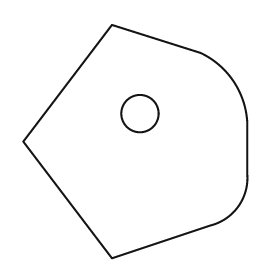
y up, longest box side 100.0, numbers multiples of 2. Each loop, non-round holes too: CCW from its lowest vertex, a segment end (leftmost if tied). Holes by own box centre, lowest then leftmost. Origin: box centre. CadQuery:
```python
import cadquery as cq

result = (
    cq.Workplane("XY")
    .moveTo(-10.0, -50.0)
    .lineTo(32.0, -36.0)
    .threePointArc((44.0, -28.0), (48.0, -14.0))
    .lineTo(48.0, 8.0)
    .threePointArc((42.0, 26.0), (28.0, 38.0))
    .lineTo(-10.0, 50.0)
    .lineTo(-48.0, 0.0)
    .close()
    .moveTo(2.0, 12.0)
    .circle(8.0)
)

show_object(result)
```